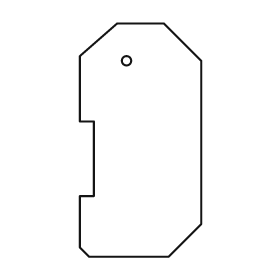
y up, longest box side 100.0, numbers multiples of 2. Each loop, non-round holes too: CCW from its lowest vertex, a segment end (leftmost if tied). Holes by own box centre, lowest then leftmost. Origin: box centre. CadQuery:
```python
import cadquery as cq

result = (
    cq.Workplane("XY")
    .moveTo(-22.0, -50.0)
    .lineTo(12.0, -50.0)
    .lineTo(26.0, -36.0)
    .lineTo(26.0, 34.0)
    .lineTo(10.0, 50.0)
    .lineTo(-10.0, 50.0)
    .lineTo(-26.0, 36.0)
    .lineTo(-26.0, 8.0)
    .lineTo(-20.0, 8.0)
    .lineTo(-20.0, -24.0)
    .lineTo(-26.0, -24.0)
    .lineTo(-26.0, -46.0)
    .close()
    .moveTo(-6.0, 34.0)
    .circle(2.0)
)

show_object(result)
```